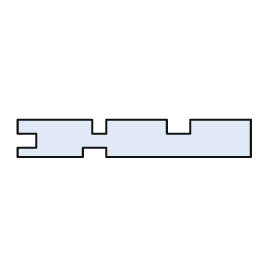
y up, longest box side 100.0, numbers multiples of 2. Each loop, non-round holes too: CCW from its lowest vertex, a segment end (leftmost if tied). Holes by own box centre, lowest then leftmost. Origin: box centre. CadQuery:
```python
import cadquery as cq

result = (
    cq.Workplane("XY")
    .moveTo(-50.0, -8.0)
    .lineTo(-22.0, -8.0)
    .lineTo(-22.0, -4.0)
    .lineTo(-12.0, -4.0)
    .lineTo(-12.0, -8.0)
    .lineTo(50.0, -8.0)
    .lineTo(50.0, 8.0)
    .lineTo(24.0, 8.0)
    .lineTo(24.0, 2.0)
    .lineTo(14.0, 2.0)
    .lineTo(14.0, 8.0)
    .lineTo(-12.0, 8.0)
    .lineTo(-12.0, 2.0)
    .lineTo(-18.0, 2.0)
    .lineTo(-18.0, 8.0)
    .lineTo(-50.0, 8.0)
    .lineTo(-50.0, 2.0)
    .lineTo(-42.0, 2.0)
    .lineTo(-42.0, -4.0)
    .lineTo(-50.0, -4.0)
    .close()
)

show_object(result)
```